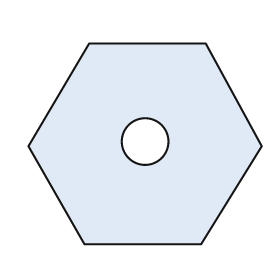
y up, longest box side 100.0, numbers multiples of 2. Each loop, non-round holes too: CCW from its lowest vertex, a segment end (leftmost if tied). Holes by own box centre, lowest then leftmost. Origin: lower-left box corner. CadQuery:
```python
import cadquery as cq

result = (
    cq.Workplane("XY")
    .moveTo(24.0, 0.0)
    .lineTo(74.0, 0.0)
    .lineTo(100.0, 42.0)
    .lineTo(76.0, 86.0)
    .lineTo(26.0, 86.0)
    .lineTo(0.0, 42.0)
    .close()
    .moveTo(50.0, 44.0)
    .circle(10.0)
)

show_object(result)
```